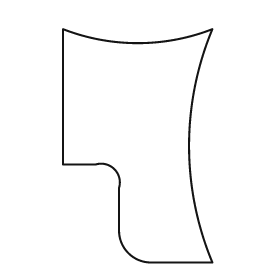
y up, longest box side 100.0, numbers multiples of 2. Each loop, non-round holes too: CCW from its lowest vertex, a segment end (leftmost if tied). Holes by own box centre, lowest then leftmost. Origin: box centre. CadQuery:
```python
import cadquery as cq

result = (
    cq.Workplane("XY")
    .moveTo(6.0, -50.0)
    .lineTo(32.0, -50.0)
    .threePointArc((22.0, 0.0), (32.0, 50.0))
    .threePointArc((0.0, 44.0), (-32.0, 50.0))
    .lineTo(-32.0, -8.0)
    .lineTo(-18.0, -8.0)
    .threePointArc((-10.0, -10.0), (-8.0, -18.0))
    .lineTo(-8.0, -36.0)
    .threePointArc((-4.0, -46.0), (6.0, -50.0))
    .close()
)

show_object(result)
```